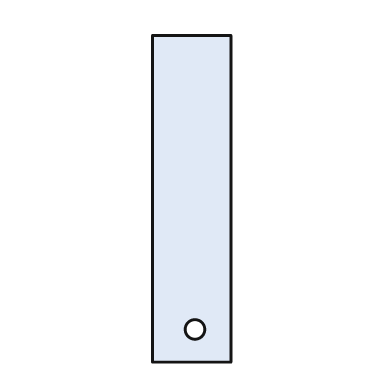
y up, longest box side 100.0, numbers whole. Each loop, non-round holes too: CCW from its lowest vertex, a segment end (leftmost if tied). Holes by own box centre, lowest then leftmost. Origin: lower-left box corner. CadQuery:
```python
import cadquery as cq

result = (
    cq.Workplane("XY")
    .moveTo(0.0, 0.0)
    .lineTo(24.0, 0.0)
    .lineTo(24.0, 100.0)
    .lineTo(0.0, 100.0)
    .close()
    .moveTo(13.0, 10.0)
    .circle(3.0)
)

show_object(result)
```